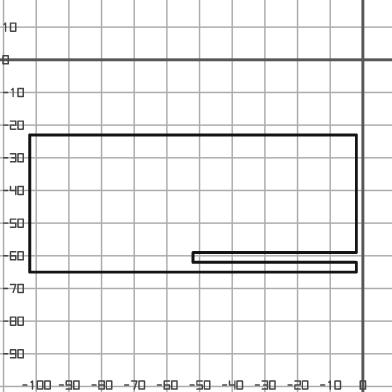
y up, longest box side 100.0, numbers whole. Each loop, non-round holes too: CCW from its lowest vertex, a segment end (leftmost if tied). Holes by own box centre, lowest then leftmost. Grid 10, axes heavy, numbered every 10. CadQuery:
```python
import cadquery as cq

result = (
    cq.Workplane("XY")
    .moveTo(-102.0, -65.0)
    .lineTo(-2.0, -65.0)
    .lineTo(-2.0, -62.0)
    .lineTo(-52.0, -62.0)
    .lineTo(-52.0, -59.0)
    .lineTo(-2.0, -59.0)
    .lineTo(-2.0, -23.0)
    .lineTo(-102.0, -23.0)
    .close()
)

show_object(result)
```